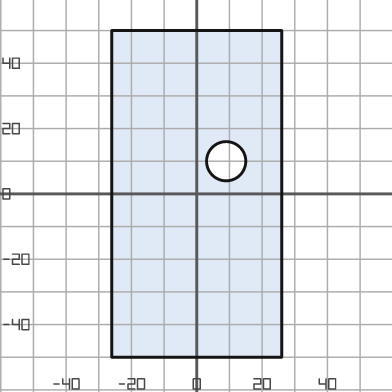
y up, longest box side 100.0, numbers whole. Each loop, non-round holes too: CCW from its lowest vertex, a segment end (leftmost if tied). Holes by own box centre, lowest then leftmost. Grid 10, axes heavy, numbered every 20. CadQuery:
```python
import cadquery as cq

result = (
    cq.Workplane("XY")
    .moveTo(-26.0, -50.0)
    .lineTo(26.0, -50.0)
    .lineTo(26.0, 50.0)
    .lineTo(-26.0, 50.0)
    .close()
    .moveTo(9.0, 10.0)
    .circle(6.0)
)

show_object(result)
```